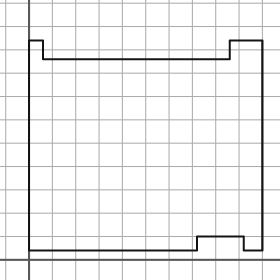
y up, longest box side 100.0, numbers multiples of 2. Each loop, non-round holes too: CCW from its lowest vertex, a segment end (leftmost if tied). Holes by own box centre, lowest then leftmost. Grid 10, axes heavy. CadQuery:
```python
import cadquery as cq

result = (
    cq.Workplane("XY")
    .moveTo(0.0, 4.0)
    .lineTo(72.0, 4.0)
    .lineTo(72.0, 10.0)
    .lineTo(92.0, 10.0)
    .lineTo(92.0, 4.0)
    .lineTo(100.0, 4.0)
    .lineTo(100.0, 94.0)
    .lineTo(86.0, 94.0)
    .lineTo(86.0, 86.0)
    .lineTo(6.0, 86.0)
    .lineTo(6.0, 94.0)
    .lineTo(0.0, 94.0)
    .close()
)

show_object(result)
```